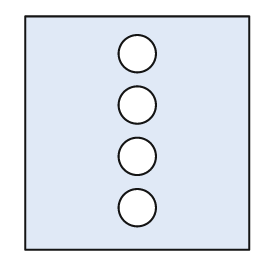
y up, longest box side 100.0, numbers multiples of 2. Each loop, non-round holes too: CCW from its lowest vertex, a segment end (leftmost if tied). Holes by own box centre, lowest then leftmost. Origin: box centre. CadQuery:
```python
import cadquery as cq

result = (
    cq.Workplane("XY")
    .moveTo(-48.0, -50.0)
    .lineTo(48.0, -50.0)
    .lineTo(48.0, 50.0)
    .lineTo(-48.0, 50.0)
    .close()
    .moveTo(0.0, -32.0)
    .circle(8.0)
    .moveTo(0.0, -10.0)
    .circle(8.0)
    .moveTo(0.0, 12.0)
    .circle(8.0)
    .moveTo(0.0, 34.0)
    .circle(8.0)
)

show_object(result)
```